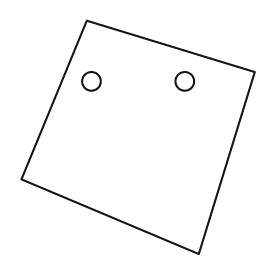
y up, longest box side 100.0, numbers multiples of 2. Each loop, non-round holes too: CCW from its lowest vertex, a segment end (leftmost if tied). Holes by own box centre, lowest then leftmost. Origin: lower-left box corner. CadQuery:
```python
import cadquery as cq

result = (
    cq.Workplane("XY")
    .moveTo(76.0, 0.0)
    .lineTo(100.0, 78.0)
    .lineTo(28.0, 100.0)
    .lineTo(0.0, 32.0)
    .close()
    .moveTo(30.0, 74.0)
    .circle(4.0)
    .moveTo(70.0, 74.0)
    .circle(4.0)
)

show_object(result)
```